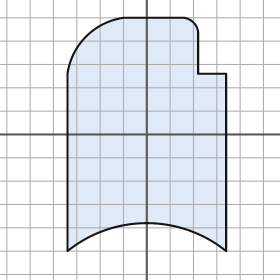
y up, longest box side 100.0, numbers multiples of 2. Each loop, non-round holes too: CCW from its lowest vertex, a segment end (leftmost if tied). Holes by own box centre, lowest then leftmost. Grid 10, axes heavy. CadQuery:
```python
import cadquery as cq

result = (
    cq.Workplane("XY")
    .moveTo(-34.0, -50.0)
    .threePointArc((0.0, -38.0), (34.0, -50.0))
    .lineTo(34.0, 26.0)
    .lineTo(22.0, 26.0)
    .lineTo(22.0, 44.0)
    .threePointArc((20.0, 48.0), (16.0, 50.0))
    .lineTo(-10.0, 50.0)
    .threePointArc((-26.0, 42.0), (-34.0, 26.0))
    .close()
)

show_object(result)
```